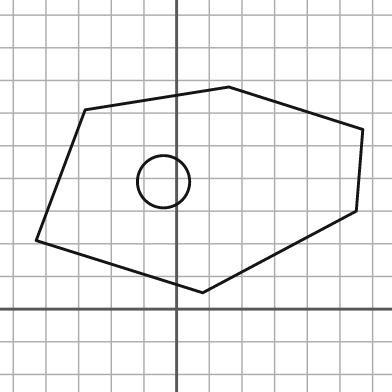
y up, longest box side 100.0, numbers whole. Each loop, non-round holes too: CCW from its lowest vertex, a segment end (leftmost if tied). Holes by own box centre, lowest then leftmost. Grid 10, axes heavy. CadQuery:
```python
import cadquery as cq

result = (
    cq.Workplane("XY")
    .moveTo(8.0, 5.0)
    .lineTo(55.0, 30.0)
    .lineTo(57.0, 55.0)
    .lineTo(16.0, 68.0)
    .lineTo(-28.0, 61.0)
    .lineTo(-43.0, 21.0)
    .close()
    .moveTo(-4.0, 39.0)
    .circle(8.0)
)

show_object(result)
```